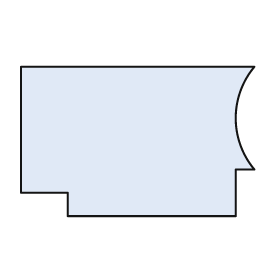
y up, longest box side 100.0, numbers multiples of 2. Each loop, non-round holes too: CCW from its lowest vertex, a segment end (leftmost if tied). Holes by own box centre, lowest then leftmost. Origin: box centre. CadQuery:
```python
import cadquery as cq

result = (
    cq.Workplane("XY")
    .moveTo(-30.0, -32.0)
    .lineTo(42.0, -32.0)
    .lineTo(42.0, -12.0)
    .lineTo(50.0, -12.0)
    .threePointArc((42.0, 10.0), (50.0, 32.0))
    .lineTo(-50.0, 32.0)
    .lineTo(-50.0, -22.0)
    .lineTo(-30.0, -22.0)
    .close()
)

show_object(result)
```